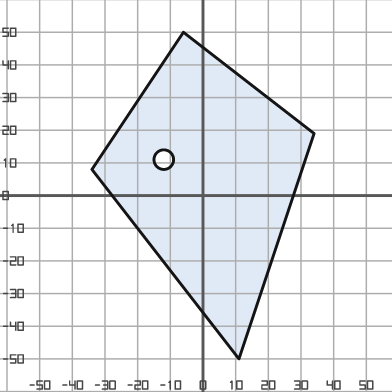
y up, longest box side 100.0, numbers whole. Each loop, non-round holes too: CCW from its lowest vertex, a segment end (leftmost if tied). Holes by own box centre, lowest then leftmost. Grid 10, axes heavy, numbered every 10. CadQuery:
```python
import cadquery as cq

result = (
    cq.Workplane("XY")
    .moveTo(11.0, -50.0)
    .lineTo(34.0, 19.0)
    .lineTo(-6.0, 50.0)
    .lineTo(-34.0, 8.0)
    .close()
    .moveTo(-12.0, 11.0)
    .circle(3.0)
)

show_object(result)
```